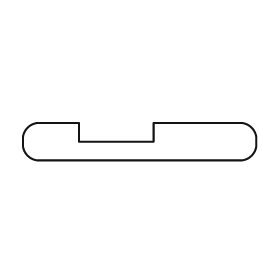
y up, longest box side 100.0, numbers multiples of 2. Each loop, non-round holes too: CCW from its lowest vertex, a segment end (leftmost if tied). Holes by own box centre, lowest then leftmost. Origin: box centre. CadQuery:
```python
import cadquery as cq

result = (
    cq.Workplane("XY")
    .moveTo(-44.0, -8.0)
    .lineTo(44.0, -8.0)
    .threePointArc((48.0, -6.0), (50.0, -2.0))
    .lineTo(50.0, 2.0)
    .threePointArc((48.0, 6.0), (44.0, 8.0))
    .lineTo(6.0, 8.0)
    .lineTo(6.0, 0.0)
    .lineTo(-26.0, 0.0)
    .lineTo(-26.0, 8.0)
    .lineTo(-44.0, 8.0)
    .threePointArc((-48.0, 6.0), (-50.0, 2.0))
    .lineTo(-50.0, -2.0)
    .threePointArc((-48.0, -6.0), (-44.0, -8.0))
    .close()
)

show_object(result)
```